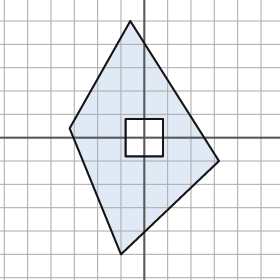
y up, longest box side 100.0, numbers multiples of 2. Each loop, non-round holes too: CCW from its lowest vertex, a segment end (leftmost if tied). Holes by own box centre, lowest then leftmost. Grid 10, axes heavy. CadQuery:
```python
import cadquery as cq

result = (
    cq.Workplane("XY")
    .moveTo(-10.0, -50.0)
    .lineTo(32.0, -10.0)
    .lineTo(-6.0, 50.0)
    .lineTo(-32.0, 4.0)
    .close()
    .moveTo(-8.0, -8.0)
    .lineTo(8.0, -8.0)
    .lineTo(8.0, 8.0)
    .lineTo(-8.0, 8.0)
    .close()
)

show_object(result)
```